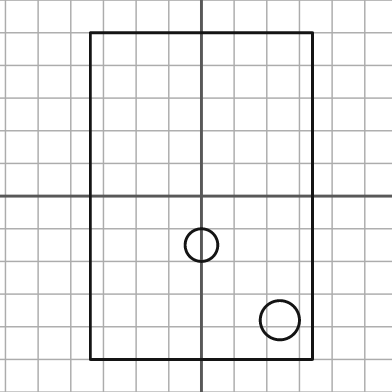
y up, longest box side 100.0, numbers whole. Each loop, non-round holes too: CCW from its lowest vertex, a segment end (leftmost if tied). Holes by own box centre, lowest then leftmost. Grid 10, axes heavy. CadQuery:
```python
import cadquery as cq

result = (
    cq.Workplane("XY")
    .moveTo(-34.0, -50.0)
    .lineTo(34.0, -50.0)
    .lineTo(34.0, 50.0)
    .lineTo(-34.0, 50.0)
    .close()
    .moveTo(24.0, -38.0)
    .circle(6.0)
    .moveTo(0.0, -15.0)
    .circle(5.0)
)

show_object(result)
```